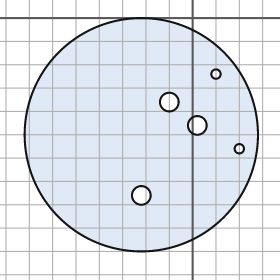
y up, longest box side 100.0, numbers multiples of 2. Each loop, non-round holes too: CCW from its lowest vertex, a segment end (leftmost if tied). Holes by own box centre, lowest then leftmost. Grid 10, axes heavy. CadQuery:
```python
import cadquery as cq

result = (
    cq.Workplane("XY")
    .moveTo(-22.0, -50.0)
    .circle(50.0)
    .moveTo(-22.0, -76.0)
    .circle(4.0)
    .moveTo(20.0, -56.0)
    .circle(2.0)
    .moveTo(2.0, -46.0)
    .circle(4.0)
    .moveTo(-10.0, -36.0)
    .circle(4.0)
    .moveTo(10.0, -24.0)
    .circle(2.0)
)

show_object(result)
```